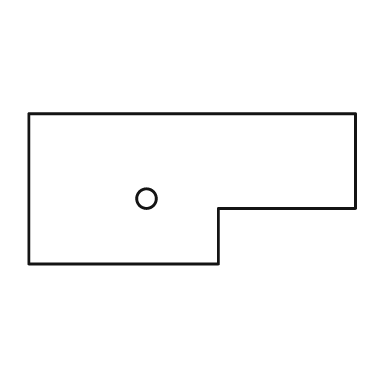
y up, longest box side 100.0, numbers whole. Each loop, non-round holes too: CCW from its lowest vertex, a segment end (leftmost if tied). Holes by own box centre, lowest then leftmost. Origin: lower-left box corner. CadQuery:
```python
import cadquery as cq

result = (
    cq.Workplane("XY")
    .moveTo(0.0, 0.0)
    .lineTo(58.0, 0.0)
    .lineTo(58.0, 17.0)
    .lineTo(100.0, 17.0)
    .lineTo(100.0, 46.0)
    .lineTo(0.0, 46.0)
    .close()
    .moveTo(36.0, 20.0)
    .circle(3.0)
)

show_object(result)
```